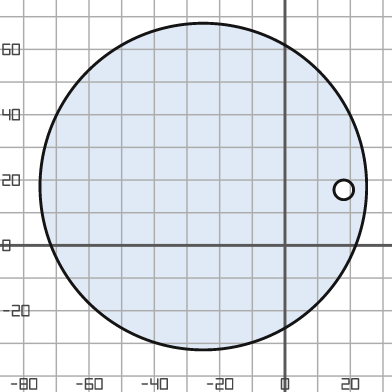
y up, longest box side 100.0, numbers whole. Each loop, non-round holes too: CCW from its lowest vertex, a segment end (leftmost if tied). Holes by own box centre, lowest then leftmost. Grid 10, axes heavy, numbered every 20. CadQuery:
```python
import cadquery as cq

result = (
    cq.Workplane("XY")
    .moveTo(-25.0, 18.0)
    .circle(50.0)
    .moveTo(18.0, 17.0)
    .circle(3.0)
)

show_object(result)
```